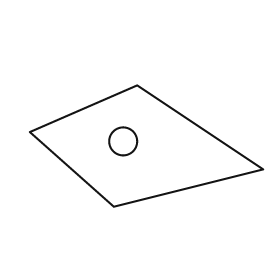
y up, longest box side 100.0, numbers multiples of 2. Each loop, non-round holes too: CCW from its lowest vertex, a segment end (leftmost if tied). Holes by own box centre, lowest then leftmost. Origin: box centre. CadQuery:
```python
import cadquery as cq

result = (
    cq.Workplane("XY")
    .moveTo(-14.0, -26.0)
    .lineTo(50.0, -10.0)
    .lineTo(-4.0, 26.0)
    .lineTo(-50.0, 6.0)
    .close()
    .moveTo(-10.0, 2.0)
    .circle(6.0)
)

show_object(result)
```